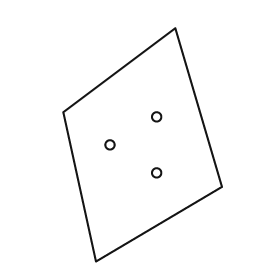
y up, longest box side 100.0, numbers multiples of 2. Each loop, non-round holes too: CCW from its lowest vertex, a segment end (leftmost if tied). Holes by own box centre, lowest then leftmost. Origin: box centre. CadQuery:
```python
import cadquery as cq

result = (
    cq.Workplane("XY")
    .moveTo(-20.0, -50.0)
    .lineTo(34.0, -18.0)
    .lineTo(14.0, 50.0)
    .lineTo(-34.0, 14.0)
    .close()
    .moveTo(6.0, -12.0)
    .circle(2.0)
    .moveTo(-14.0, 0.0)
    .circle(2.0)
    .moveTo(6.0, 12.0)
    .circle(2.0)
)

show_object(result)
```